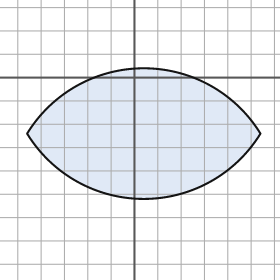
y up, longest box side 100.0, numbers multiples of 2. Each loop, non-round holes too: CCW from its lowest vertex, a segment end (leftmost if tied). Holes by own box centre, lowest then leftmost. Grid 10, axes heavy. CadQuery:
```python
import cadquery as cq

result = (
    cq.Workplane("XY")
    .moveTo(-46.0, -24.0)
    .threePointArc((4.0, -52.0), (54.0, -24.0))
    .threePointArc((4.0, 4.0), (-46.0, -24.0))
    .close()
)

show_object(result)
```